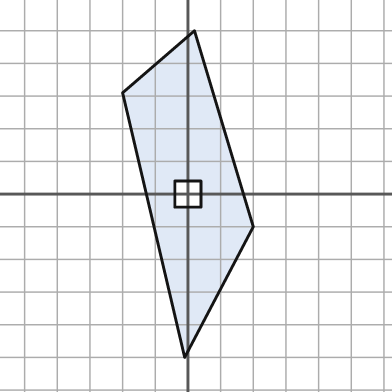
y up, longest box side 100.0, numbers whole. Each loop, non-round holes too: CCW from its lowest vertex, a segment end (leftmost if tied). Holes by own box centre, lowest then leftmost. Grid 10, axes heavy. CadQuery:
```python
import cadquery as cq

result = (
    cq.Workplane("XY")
    .moveTo(-1.0, -50.0)
    .lineTo(20.0, -10.0)
    .lineTo(2.0, 50.0)
    .lineTo(-20.0, 31.0)
    .close()
    .moveTo(-4.0, -4.0)
    .lineTo(4.0, -4.0)
    .lineTo(4.0, 4.0)
    .lineTo(-4.0, 4.0)
    .close()
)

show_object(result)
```